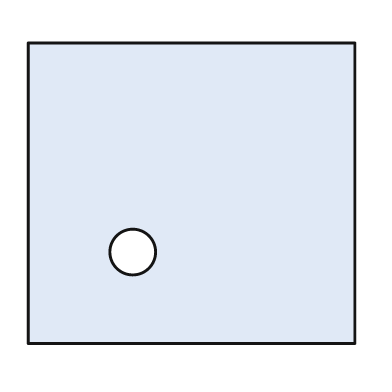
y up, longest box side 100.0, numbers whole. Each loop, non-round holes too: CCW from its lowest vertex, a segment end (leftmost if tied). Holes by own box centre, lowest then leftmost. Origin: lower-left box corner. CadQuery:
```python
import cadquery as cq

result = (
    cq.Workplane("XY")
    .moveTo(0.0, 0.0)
    .lineTo(100.0, 0.0)
    .lineTo(100.0, 92.0)
    .lineTo(0.0, 92.0)
    .close()
    .moveTo(32.0, 28.0)
    .circle(7.0)
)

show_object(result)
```